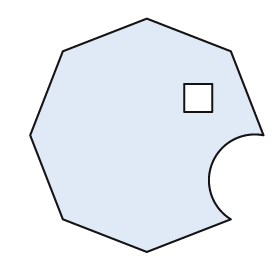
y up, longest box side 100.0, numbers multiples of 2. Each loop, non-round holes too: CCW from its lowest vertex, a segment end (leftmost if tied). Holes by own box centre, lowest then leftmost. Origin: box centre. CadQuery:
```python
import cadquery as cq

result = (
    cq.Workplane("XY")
    .moveTo(0.0, -50.0)
    .lineTo(36.0, -36.0)
    .threePointArc((28.0, -12.0), (50.0, 0.0))
    .lineTo(36.0, 36.0)
    .lineTo(0.0, 50.0)
    .lineTo(-36.0, 36.0)
    .lineTo(-50.0, 0.0)
    .lineTo(-36.0, -36.0)
    .close()
    .moveTo(16.0, 10.0)
    .lineTo(28.0, 10.0)
    .lineTo(28.0, 22.0)
    .lineTo(16.0, 22.0)
    .close()
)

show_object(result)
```